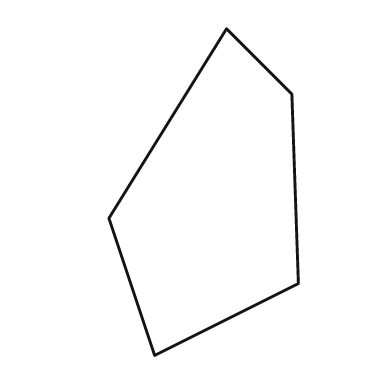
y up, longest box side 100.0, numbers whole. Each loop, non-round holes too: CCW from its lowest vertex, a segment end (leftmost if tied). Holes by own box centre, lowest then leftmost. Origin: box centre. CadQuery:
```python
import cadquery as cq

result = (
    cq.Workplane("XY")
    .moveTo(-15.0, -50.0)
    .lineTo(29.0, -28.0)
    .lineTo(27.0, 30.0)
    .lineTo(7.0, 50.0)
    .lineTo(-29.0, -8.0)
    .close()
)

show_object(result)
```